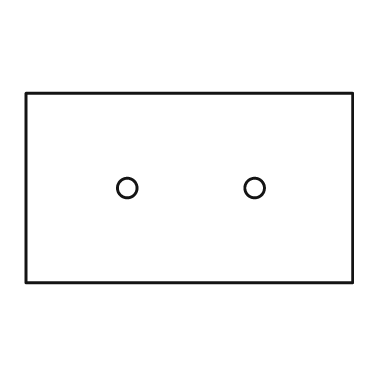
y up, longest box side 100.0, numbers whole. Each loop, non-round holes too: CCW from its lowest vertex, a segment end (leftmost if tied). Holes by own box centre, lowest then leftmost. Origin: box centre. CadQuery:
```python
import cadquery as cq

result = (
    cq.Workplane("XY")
    .moveTo(-50.0, -29.0)
    .lineTo(50.0, -29.0)
    .lineTo(50.0, 29.0)
    .lineTo(-50.0, 29.0)
    .close()
    .moveTo(-19.0, 0.0)
    .circle(3.0)
    .moveTo(20.0, 0.0)
    .circle(3.0)
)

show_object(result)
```